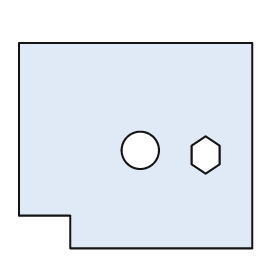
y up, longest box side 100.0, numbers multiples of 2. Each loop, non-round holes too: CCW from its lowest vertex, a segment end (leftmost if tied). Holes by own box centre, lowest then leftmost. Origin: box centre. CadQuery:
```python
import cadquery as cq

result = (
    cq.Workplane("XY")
    .moveTo(-28.0, -44.0)
    .lineTo(50.0, -44.0)
    .lineTo(50.0, 44.0)
    .lineTo(-50.0, 44.0)
    .lineTo(-50.0, -30.0)
    .lineTo(-28.0, -30.0)
    .close()
    .moveTo(30.0, -12.0)
    .lineTo(36.0, -8.0)
    .lineTo(36.0, 0.0)
    .lineTo(30.0, 4.0)
    .lineTo(24.0, 0.0)
    .lineTo(24.0, -8.0)
    .close()
    .moveTo(2.0, -2.0)
    .circle(8.0)
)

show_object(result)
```